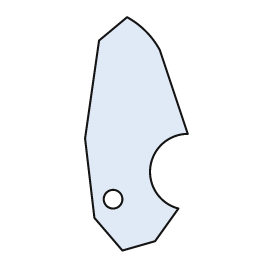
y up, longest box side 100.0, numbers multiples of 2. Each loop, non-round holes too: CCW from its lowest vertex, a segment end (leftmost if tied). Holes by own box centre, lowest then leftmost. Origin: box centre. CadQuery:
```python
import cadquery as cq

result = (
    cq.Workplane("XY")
    .moveTo(-6.0, -50.0)
    .lineTo(8.0, -46.0)
    .lineTo(18.0, -32.0)
    .threePointArc((6.0, -14.0), (22.0, 0.0))
    .lineTo(10.0, 36.0)
    .threePointArc((4.0, 44.0), (-4.0, 50.0))
    .lineTo(-16.0, 40.0)
    .lineTo(-22.0, -2.0)
    .lineTo(-18.0, -36.0)
    .close()
    .moveTo(-10.0, -28.0)
    .circle(4.0)
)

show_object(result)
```